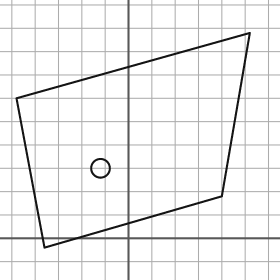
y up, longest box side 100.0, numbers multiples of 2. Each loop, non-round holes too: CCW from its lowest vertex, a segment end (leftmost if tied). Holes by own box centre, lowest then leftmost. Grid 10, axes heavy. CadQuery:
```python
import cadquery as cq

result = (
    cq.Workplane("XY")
    .moveTo(-36.0, -4.0)
    .lineTo(40.0, 18.0)
    .lineTo(52.0, 88.0)
    .lineTo(-48.0, 60.0)
    .close()
    .moveTo(-12.0, 30.0)
    .circle(4.0)
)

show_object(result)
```